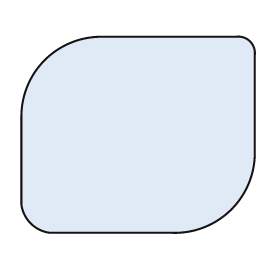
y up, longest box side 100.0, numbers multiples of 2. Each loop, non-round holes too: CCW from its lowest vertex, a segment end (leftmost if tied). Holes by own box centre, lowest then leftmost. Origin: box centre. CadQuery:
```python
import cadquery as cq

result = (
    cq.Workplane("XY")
    .moveTo(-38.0, -42.0)
    .lineTo(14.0, -42.0)
    .threePointArc((40.0, -32.0), (50.0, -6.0))
    .lineTo(50.0, 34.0)
    .threePointArc((48.0, 40.0), (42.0, 42.0))
    .lineTo(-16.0, 42.0)
    .threePointArc((-40.0, 32.0), (-50.0, 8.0))
    .lineTo(-50.0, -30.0)
    .threePointArc((-46.0, -38.0), (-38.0, -42.0))
    .close()
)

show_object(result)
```